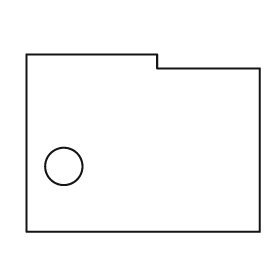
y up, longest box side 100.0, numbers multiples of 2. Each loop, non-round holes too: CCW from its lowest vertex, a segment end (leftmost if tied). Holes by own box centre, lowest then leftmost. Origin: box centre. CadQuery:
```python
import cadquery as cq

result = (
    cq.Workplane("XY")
    .moveTo(-50.0, -38.0)
    .lineTo(50.0, -38.0)
    .lineTo(50.0, 32.0)
    .lineTo(6.0, 32.0)
    .lineTo(6.0, 38.0)
    .lineTo(-50.0, 38.0)
    .close()
    .moveTo(-34.0, -10.0)
    .circle(8.0)
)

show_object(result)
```